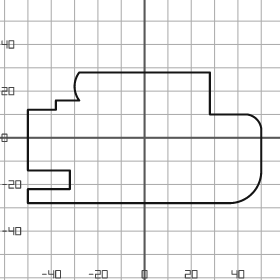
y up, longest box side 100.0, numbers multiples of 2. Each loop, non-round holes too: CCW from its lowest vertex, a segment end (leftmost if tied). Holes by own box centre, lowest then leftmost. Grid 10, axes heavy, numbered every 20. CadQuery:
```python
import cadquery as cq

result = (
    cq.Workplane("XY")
    .moveTo(-50.0, -28.0)
    .lineTo(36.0, -28.0)
    .threePointArc((46.0, -24.0), (50.0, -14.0))
    .lineTo(50.0, 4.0)
    .threePointArc((48.0, 8.0), (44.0, 10.0))
    .lineTo(28.0, 10.0)
    .lineTo(28.0, 28.0)
    .lineTo(-28.0, 28.0)
    .threePointArc((-30.0, 22.0), (-28.0, 16.0))
    .lineTo(-38.0, 16.0)
    .lineTo(-38.0, 12.0)
    .lineTo(-50.0, 12.0)
    .lineTo(-50.0, -14.0)
    .lineTo(-32.0, -14.0)
    .lineTo(-32.0, -22.0)
    .lineTo(-50.0, -22.0)
    .close()
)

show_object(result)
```